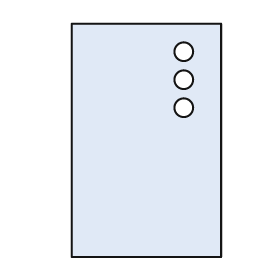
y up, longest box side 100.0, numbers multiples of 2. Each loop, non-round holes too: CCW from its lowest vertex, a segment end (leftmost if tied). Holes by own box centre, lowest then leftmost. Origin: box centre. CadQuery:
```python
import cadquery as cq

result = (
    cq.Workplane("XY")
    .moveTo(-32.0, -50.0)
    .lineTo(32.0, -50.0)
    .lineTo(32.0, 50.0)
    .lineTo(-32.0, 50.0)
    .close()
    .moveTo(16.0, 14.0)
    .circle(4.0)
    .moveTo(16.0, 26.0)
    .circle(4.0)
    .moveTo(16.0, 38.0)
    .circle(4.0)
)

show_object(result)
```